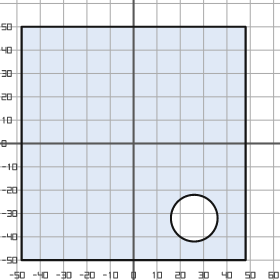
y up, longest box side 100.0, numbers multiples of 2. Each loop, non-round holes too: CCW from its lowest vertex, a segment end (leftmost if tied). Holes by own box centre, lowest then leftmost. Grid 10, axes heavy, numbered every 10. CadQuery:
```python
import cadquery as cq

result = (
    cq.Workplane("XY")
    .moveTo(-48.0, -50.0)
    .lineTo(48.0, -50.0)
    .lineTo(48.0, 50.0)
    .lineTo(-48.0, 50.0)
    .close()
    .moveTo(26.0, -32.0)
    .circle(10.0)
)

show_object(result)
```